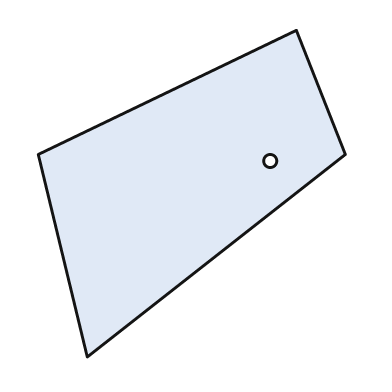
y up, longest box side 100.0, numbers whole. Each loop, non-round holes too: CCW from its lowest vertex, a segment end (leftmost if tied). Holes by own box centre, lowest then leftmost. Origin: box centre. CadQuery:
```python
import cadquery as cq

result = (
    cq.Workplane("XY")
    .moveTo(-32.0, -50.0)
    .lineTo(47.0, 12.0)
    .lineTo(32.0, 50.0)
    .lineTo(-47.0, 12.0)
    .close()
    .moveTo(24.0, 10.0)
    .circle(2.0)
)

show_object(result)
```